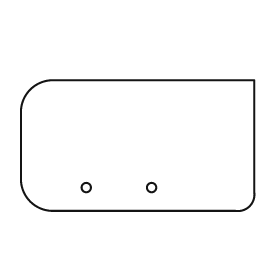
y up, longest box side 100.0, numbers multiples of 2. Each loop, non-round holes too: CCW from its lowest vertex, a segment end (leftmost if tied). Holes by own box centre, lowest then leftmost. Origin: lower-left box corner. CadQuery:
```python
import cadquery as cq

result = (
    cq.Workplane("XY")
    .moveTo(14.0, 0.0)
    .lineTo(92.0, 0.0)
    .threePointArc((98.0, 2.0), (100.0, 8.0))
    .lineTo(100.0, 56.0)
    .lineTo(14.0, 56.0)
    .threePointArc((4.0, 52.0), (0.0, 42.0))
    .lineTo(0.0, 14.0)
    .threePointArc((4.0, 4.0), (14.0, 0.0))
    .close()
    .moveTo(28.0, 10.0)
    .circle(2.0)
    .moveTo(56.0, 10.0)
    .circle(2.0)
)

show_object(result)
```